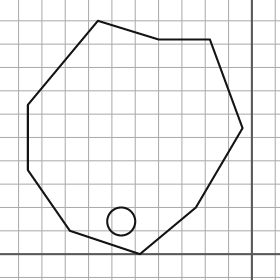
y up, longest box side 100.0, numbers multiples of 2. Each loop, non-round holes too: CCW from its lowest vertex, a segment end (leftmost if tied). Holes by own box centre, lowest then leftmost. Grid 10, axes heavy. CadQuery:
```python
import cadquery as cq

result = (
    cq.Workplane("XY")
    .moveTo(-48.0, 0.0)
    .lineTo(-24.0, 20.0)
    .lineTo(-4.0, 54.0)
    .lineTo(-18.0, 92.0)
    .lineTo(-40.0, 92.0)
    .lineTo(-66.0, 100.0)
    .lineTo(-96.0, 64.0)
    .lineTo(-96.0, 36.0)
    .lineTo(-78.0, 10.0)
    .close()
    .moveTo(-56.0, 14.0)
    .circle(6.0)
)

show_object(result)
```